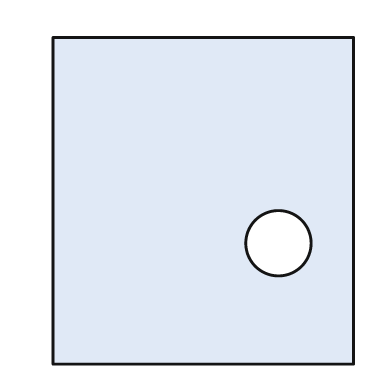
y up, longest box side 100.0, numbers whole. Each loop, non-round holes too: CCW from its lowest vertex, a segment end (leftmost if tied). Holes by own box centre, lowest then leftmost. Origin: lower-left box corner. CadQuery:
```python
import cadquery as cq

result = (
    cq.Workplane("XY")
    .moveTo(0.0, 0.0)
    .lineTo(92.0, 0.0)
    .lineTo(92.0, 100.0)
    .lineTo(0.0, 100.0)
    .close()
    .moveTo(69.0, 37.0)
    .circle(10.0)
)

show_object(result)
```